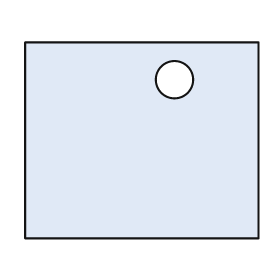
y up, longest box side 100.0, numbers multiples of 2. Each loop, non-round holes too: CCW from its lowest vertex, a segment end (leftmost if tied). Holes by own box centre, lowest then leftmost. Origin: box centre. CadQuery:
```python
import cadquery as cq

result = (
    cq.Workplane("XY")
    .moveTo(-50.0, -42.0)
    .lineTo(50.0, -42.0)
    .lineTo(50.0, 42.0)
    .lineTo(-50.0, 42.0)
    .close()
    .moveTo(14.0, 26.0)
    .circle(8.0)
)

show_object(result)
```